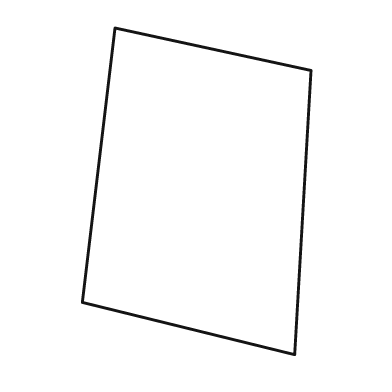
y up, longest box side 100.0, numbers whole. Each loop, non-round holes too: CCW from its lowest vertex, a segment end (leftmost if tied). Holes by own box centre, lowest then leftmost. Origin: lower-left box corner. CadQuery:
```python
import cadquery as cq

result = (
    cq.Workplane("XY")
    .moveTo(65.0, 0.0)
    .lineTo(70.0, 87.0)
    .lineTo(10.0, 100.0)
    .lineTo(0.0, 16.0)
    .close()
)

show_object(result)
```